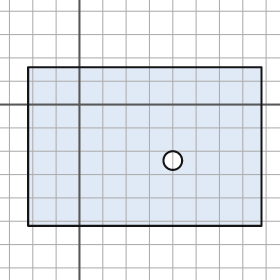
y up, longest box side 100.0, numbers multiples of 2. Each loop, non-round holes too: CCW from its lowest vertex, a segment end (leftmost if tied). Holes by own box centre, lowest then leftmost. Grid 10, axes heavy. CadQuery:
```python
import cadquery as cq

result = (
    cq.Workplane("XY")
    .moveTo(-22.0, -52.0)
    .lineTo(78.0, -52.0)
    .lineTo(78.0, 16.0)
    .lineTo(-22.0, 16.0)
    .close()
    .moveTo(40.0, -24.0)
    .circle(4.0)
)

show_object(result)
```